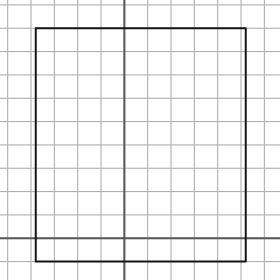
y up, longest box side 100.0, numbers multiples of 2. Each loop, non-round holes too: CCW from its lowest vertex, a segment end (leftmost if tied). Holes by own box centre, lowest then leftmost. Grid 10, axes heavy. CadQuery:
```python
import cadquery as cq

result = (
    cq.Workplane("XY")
    .moveTo(-38.0, -10.0)
    .lineTo(52.0, -10.0)
    .lineTo(52.0, 90.0)
    .lineTo(-38.0, 90.0)
    .close()
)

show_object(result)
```